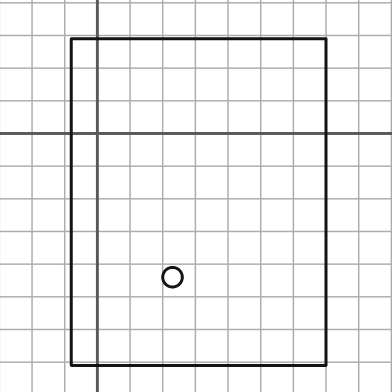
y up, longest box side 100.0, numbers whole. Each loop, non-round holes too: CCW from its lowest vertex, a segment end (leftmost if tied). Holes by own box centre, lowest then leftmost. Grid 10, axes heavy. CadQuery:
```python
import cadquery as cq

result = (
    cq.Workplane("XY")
    .moveTo(-8.0, -71.0)
    .lineTo(70.0, -71.0)
    .lineTo(70.0, 29.0)
    .lineTo(-8.0, 29.0)
    .close()
    .moveTo(23.0, -44.0)
    .circle(3.0)
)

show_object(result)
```